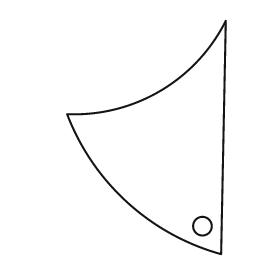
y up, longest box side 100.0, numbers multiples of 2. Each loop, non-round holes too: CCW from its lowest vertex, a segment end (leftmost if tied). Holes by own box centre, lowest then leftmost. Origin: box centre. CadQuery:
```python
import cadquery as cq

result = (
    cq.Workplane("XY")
    .moveTo(32.0, -50.0)
    .lineTo(34.0, 50.0)
    .threePointArc((6.0, 20.0), (-34.0, 10.0))
    .threePointArc((-8.0, -28.0), (32.0, -50.0))
    .close()
    .moveTo(24.0, -38.0)
    .circle(4.0)
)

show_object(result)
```